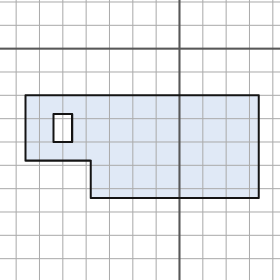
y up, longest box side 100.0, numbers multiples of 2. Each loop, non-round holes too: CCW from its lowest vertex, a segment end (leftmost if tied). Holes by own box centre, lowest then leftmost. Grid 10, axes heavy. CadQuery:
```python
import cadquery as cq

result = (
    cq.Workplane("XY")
    .moveTo(-38.0, -64.0)
    .lineTo(34.0, -64.0)
    .lineTo(34.0, -20.0)
    .lineTo(-66.0, -20.0)
    .lineTo(-66.0, -48.0)
    .lineTo(-38.0, -48.0)
    .close()
    .moveTo(-54.0, -40.0)
    .lineTo(-46.0, -40.0)
    .lineTo(-46.0, -28.0)
    .lineTo(-54.0, -28.0)
    .close()
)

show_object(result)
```